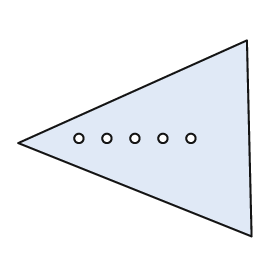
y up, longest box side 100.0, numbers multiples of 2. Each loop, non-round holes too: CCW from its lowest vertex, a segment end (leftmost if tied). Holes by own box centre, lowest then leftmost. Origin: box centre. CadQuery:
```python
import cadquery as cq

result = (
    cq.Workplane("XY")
    .moveTo(50.0, -42.0)
    .lineTo(48.0, 42.0)
    .lineTo(-50.0, -2.0)
    .close()
    .moveTo(-24.0, 0.0)
    .circle(2.0)
    .moveTo(-12.0, 0.0)
    .circle(2.0)
    .moveTo(0.0, 0.0)
    .circle(2.0)
    .moveTo(12.0, 0.0)
    .circle(2.0)
    .moveTo(24.0, 0.0)
    .circle(2.0)
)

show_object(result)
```